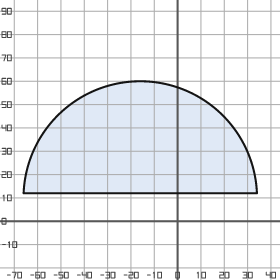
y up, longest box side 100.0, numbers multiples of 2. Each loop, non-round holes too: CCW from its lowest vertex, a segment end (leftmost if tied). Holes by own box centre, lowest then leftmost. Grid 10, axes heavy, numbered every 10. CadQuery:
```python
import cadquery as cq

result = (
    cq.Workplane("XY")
    .moveTo(-66.0, 12.0)
    .lineTo(34.0, 12.0)
    .threePointArc((-16.0, 60.0), (-66.0, 12.0))
    .close()
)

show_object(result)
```